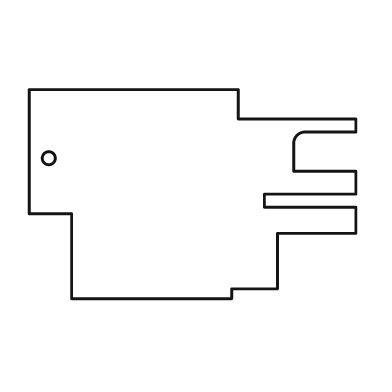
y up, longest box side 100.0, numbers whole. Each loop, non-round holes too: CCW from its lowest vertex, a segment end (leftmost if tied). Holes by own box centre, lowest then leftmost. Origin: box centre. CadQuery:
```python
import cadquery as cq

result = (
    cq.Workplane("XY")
    .moveTo(-37.0, -32.0)
    .lineTo(12.0, -32.0)
    .lineTo(12.0, -29.0)
    .lineTo(26.0, -29.0)
    .lineTo(26.0, -12.0)
    .lineTo(50.0, -12.0)
    .lineTo(50.0, -4.0)
    .lineTo(22.0, -4.0)
    .lineTo(22.0, 0.0)
    .lineTo(50.0, 0.0)
    .lineTo(50.0, 7.0)
    .lineTo(31.0, 7.0)
    .lineTo(31.0, 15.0)
    .threePointArc((32.0, 18.0), (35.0, 19.0))
    .lineTo(50.0, 19.0)
    .lineTo(50.0, 23.0)
    .lineTo(14.0, 23.0)
    .lineTo(14.0, 32.0)
    .lineTo(-50.0, 32.0)
    .lineTo(-50.0, -6.0)
    .lineTo(-37.0, -6.0)
    .close()
    .moveTo(-44.0, 11.0)
    .circle(2.0)
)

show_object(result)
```